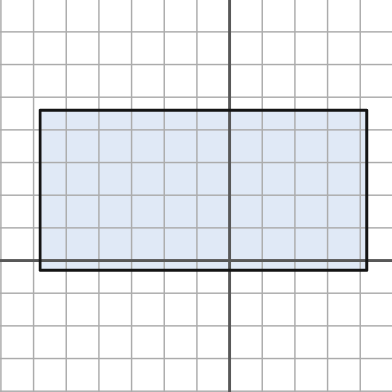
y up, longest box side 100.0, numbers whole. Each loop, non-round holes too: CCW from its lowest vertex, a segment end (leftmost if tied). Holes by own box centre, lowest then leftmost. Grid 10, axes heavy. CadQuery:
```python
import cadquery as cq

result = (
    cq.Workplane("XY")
    .moveTo(-58.0, -3.0)
    .lineTo(42.0, -3.0)
    .lineTo(42.0, 46.0)
    .lineTo(-58.0, 46.0)
    .close()
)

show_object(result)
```